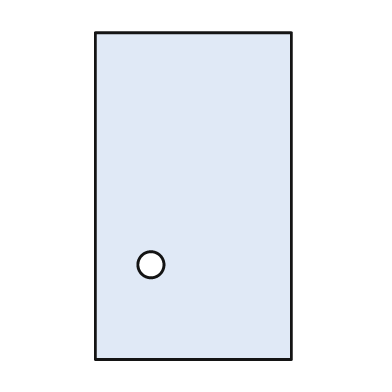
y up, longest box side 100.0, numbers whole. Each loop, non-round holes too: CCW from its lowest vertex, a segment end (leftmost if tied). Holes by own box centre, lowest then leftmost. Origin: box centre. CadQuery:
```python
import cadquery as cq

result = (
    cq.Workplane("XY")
    .moveTo(-30.0, -50.0)
    .lineTo(30.0, -50.0)
    .lineTo(30.0, 50.0)
    .lineTo(-30.0, 50.0)
    .close()
    .moveTo(-13.0, -21.0)
    .circle(4.0)
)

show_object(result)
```